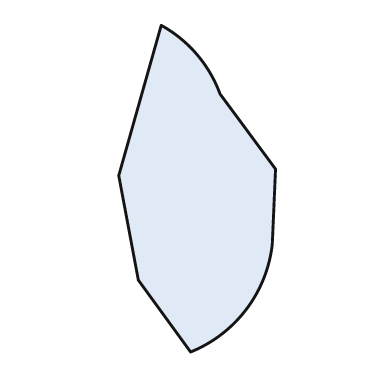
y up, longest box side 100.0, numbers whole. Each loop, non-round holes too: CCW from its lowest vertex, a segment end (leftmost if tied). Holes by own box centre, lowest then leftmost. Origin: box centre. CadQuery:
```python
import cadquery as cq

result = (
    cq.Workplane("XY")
    .moveTo(-2.0, -50.0)
    .threePointArc((15.0, -37.0), (23.0, -17.0))
    .lineTo(24.0, 6.0)
    .lineTo(7.0, 29.0)
    .threePointArc((0.0, 41.0), (-11.0, 50.0))
    .lineTo(-24.0, 4.0)
    .lineTo(-18.0, -28.0)
    .close()
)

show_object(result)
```